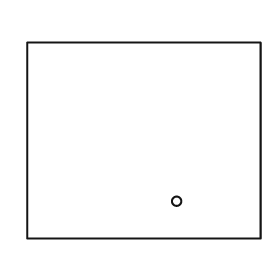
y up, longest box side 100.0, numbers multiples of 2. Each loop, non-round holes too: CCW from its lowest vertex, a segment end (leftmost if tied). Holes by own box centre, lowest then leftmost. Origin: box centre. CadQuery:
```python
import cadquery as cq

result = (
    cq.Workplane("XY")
    .moveTo(-50.0, -42.0)
    .lineTo(50.0, -42.0)
    .lineTo(50.0, 42.0)
    .lineTo(-50.0, 42.0)
    .close()
    .moveTo(14.0, -26.0)
    .circle(2.0)
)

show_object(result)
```